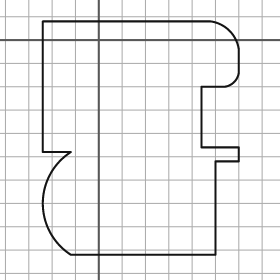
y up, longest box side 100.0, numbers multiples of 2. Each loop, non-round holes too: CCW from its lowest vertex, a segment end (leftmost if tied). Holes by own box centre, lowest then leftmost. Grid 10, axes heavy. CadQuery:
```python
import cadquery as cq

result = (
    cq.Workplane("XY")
    .moveTo(-12.0, -92.0)
    .lineTo(50.0, -92.0)
    .lineTo(50.0, -52.0)
    .lineTo(60.0, -52.0)
    .lineTo(60.0, -46.0)
    .lineTo(44.0, -46.0)
    .lineTo(44.0, -20.0)
    .lineTo(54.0, -20.0)
    .threePointArc((58.0, -18.0), (60.0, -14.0))
    .lineTo(60.0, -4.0)
    .threePointArc((56.0, 4.0), (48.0, 8.0))
    .lineTo(-24.0, 8.0)
    .lineTo(-24.0, -48.0)
    .lineTo(-12.0, -48.0)
    .threePointArc((-24.0, -70.0), (-12.0, -92.0))
    .close()
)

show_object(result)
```